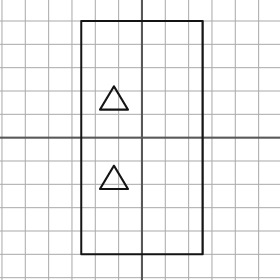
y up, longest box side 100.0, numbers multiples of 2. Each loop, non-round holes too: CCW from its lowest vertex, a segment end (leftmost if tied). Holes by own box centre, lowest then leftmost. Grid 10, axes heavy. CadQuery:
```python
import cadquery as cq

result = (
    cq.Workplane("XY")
    .moveTo(-26.0, -50.0)
    .lineTo(26.0, -50.0)
    .lineTo(26.0, 50.0)
    .lineTo(-26.0, 50.0)
    .close()
    .moveTo(-18.0, -22.0)
    .lineTo(-6.0, -22.0)
    .lineTo(-12.0, -12.0)
    .close()
    .moveTo(-18.0, 12.0)
    .lineTo(-6.0, 12.0)
    .lineTo(-12.0, 22.0)
    .close()
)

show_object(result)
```